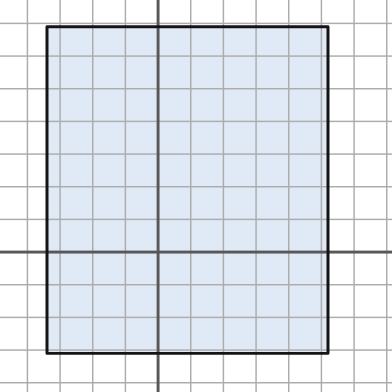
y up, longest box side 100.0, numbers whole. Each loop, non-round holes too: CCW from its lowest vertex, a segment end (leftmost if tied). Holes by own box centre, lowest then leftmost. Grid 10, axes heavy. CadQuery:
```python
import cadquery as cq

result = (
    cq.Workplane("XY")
    .moveTo(-34.0, -31.0)
    .lineTo(52.0, -31.0)
    .lineTo(52.0, 69.0)
    .lineTo(-34.0, 69.0)
    .close()
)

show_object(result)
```